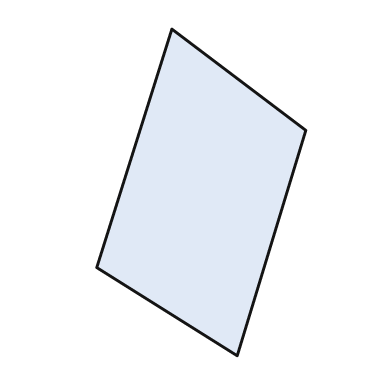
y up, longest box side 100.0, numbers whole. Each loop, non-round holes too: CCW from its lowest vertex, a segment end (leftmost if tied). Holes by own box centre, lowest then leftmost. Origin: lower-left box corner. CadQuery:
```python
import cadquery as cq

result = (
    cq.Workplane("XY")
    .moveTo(43.0, 0.0)
    .lineTo(64.0, 69.0)
    .lineTo(23.0, 100.0)
    .lineTo(0.0, 27.0)
    .close()
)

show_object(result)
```